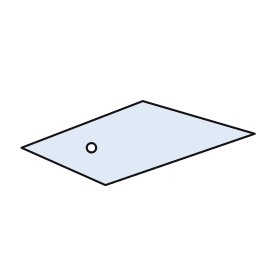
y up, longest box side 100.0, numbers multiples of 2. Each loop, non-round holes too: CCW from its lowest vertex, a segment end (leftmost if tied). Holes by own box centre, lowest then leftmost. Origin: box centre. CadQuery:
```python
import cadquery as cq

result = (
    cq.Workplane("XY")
    .moveTo(-14.0, -18.0)
    .lineTo(50.0, 4.0)
    .lineTo(2.0, 18.0)
    .lineTo(-50.0, -2.0)
    .close()
    .moveTo(-20.0, -2.0)
    .circle(2.0)
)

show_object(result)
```